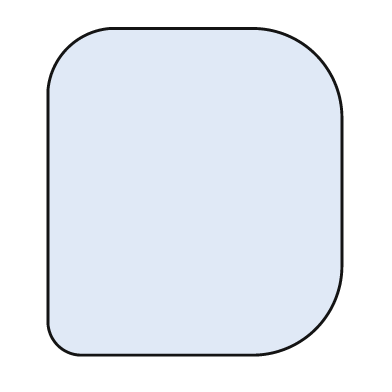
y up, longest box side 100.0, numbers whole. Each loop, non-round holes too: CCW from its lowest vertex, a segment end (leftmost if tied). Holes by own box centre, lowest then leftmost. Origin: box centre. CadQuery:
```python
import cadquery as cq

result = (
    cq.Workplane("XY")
    .moveTo(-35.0, -50.0)
    .lineTo(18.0, -50.0)
    .threePointArc((37.0, -42.0), (45.0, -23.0))
    .lineTo(45.0, 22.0)
    .threePointArc((37.0, 42.0), (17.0, 50.0))
    .lineTo(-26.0, 50.0)
    .threePointArc((-39.0, 44.0), (-45.0, 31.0))
    .lineTo(-45.0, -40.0)
    .threePointArc((-42.0, -47.0), (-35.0, -50.0))
    .close()
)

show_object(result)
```